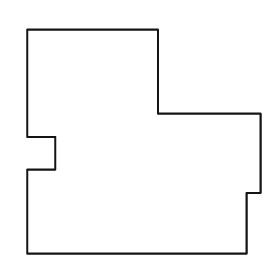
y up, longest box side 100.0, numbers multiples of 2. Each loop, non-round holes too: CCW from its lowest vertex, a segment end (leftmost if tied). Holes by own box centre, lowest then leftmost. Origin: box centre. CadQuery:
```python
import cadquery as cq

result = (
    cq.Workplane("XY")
    .moveTo(-50.0, -48.0)
    .lineTo(44.0, -48.0)
    .lineTo(44.0, -22.0)
    .lineTo(50.0, -22.0)
    .lineTo(50.0, 12.0)
    .lineTo(6.0, 12.0)
    .lineTo(6.0, 48.0)
    .lineTo(-50.0, 48.0)
    .lineTo(-50.0, 2.0)
    .lineTo(-38.0, 2.0)
    .lineTo(-38.0, -12.0)
    .lineTo(-50.0, -12.0)
    .close()
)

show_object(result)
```